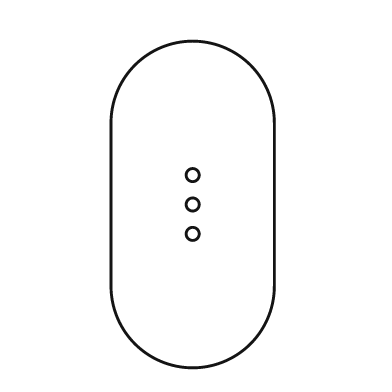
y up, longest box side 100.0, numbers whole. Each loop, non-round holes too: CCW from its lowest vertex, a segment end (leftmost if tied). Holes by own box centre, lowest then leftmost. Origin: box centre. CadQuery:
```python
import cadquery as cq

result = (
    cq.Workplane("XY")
    .moveTo(-25.0, -25.0)
    .threePointArc((0.0, -50.0), (25.0, -25.0))
    .lineTo(25.0, 25.0)
    .threePointArc((0.0, 50.0), (-25.0, 25.0))
    .close()
    .moveTo(0.0, -9.0)
    .circle(2.0)
    .moveTo(0.0, 0.0)
    .circle(2.0)
    .moveTo(0.0, 9.0)
    .circle(2.0)
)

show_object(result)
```